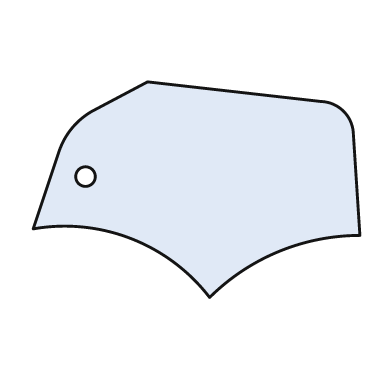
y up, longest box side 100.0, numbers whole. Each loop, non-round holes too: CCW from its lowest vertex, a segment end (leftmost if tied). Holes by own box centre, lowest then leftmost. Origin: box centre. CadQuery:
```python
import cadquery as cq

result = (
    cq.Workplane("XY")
    .moveTo(4.0, -33.0)
    .threePointArc((25.0, -19.0), (50.0, -14.0))
    .lineTo(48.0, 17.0)
    .threePointArc((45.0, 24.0), (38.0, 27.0))
    .lineTo(-15.0, 33.0)
    .lineTo(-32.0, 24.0)
    .threePointArc((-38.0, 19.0), (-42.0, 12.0))
    .lineTo(-50.0, -12.0)
    .threePointArc((-20.0, -15.0), (4.0, -33.0))
    .close()
    .moveTo(-34.0, 4.0)
    .circle(3.0)
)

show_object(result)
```